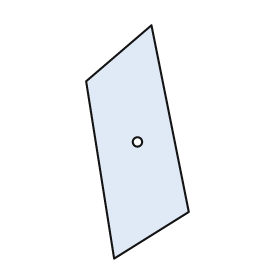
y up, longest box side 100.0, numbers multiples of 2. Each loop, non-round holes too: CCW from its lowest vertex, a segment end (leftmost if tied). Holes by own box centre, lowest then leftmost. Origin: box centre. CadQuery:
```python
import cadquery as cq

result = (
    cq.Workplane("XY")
    .moveTo(-10.0, -50.0)
    .lineTo(22.0, -30.0)
    .lineTo(6.0, 50.0)
    .lineTo(-22.0, 26.0)
    .close()
    .moveTo(0.0, 0.0)
    .circle(2.0)
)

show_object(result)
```